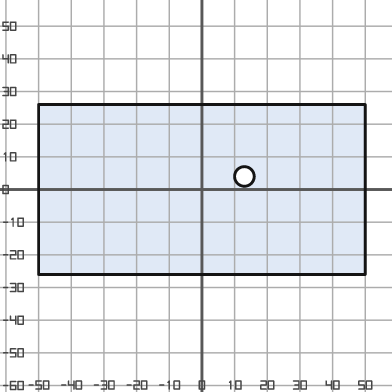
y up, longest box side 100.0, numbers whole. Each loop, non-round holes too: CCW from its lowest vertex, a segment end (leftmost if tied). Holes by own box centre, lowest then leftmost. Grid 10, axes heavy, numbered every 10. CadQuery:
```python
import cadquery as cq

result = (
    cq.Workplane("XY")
    .moveTo(-50.0, -26.0)
    .lineTo(50.0, -26.0)
    .lineTo(50.0, 26.0)
    .lineTo(-50.0, 26.0)
    .close()
    .moveTo(13.0, 4.0)
    .circle(3.0)
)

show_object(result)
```